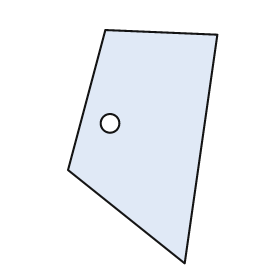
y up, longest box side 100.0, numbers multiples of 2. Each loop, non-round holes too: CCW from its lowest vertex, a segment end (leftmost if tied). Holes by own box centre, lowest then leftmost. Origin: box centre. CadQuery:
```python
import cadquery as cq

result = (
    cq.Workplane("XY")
    .moveTo(18.0, -50.0)
    .lineTo(32.0, 48.0)
    .lineTo(-16.0, 50.0)
    .lineTo(-32.0, -10.0)
    .close()
    .moveTo(-14.0, 10.0)
    .circle(4.0)
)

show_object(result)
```